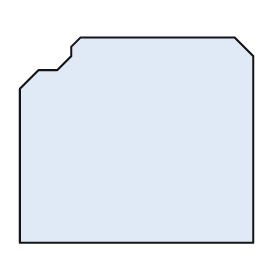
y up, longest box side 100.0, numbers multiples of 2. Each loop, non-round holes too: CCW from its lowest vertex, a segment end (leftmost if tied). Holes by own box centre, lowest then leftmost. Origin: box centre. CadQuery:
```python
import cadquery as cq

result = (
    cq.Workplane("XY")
    .moveTo(-50.0, -44.0)
    .lineTo(50.0, -44.0)
    .lineTo(50.0, 36.0)
    .lineTo(42.0, 44.0)
    .lineTo(-24.0, 44.0)
    .lineTo(-28.0, 40.0)
    .lineTo(-28.0, 36.0)
    .lineTo(-34.0, 30.0)
    .lineTo(-42.0, 30.0)
    .lineTo(-50.0, 22.0)
    .close()
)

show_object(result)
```